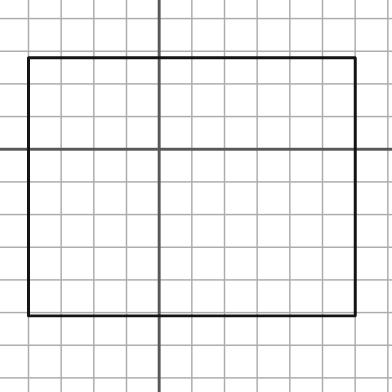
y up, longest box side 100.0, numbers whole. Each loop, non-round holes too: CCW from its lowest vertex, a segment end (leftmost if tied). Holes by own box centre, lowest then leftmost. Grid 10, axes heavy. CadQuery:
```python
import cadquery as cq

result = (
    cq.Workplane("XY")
    .moveTo(-40.0, -51.0)
    .lineTo(60.0, -51.0)
    .lineTo(60.0, 28.0)
    .lineTo(-40.0, 28.0)
    .close()
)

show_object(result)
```